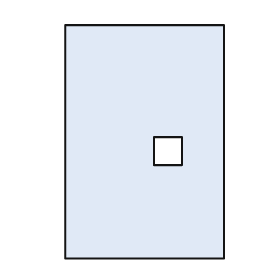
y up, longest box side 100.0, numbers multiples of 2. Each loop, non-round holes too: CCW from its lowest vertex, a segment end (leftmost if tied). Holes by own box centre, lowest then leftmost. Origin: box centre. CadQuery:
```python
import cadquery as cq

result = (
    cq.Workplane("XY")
    .moveTo(-34.0, -50.0)
    .lineTo(34.0, -50.0)
    .lineTo(34.0, 50.0)
    .lineTo(-34.0, 50.0)
    .close()
    .moveTo(4.0, -10.0)
    .lineTo(16.0, -10.0)
    .lineTo(16.0, 2.0)
    .lineTo(4.0, 2.0)
    .close()
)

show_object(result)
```